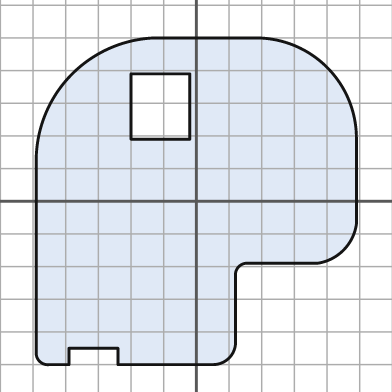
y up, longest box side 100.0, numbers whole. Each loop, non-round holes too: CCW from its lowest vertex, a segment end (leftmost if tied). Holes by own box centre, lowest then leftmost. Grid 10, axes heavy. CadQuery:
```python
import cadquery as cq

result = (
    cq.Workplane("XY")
    .moveTo(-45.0, -50.0)
    .lineTo(-39.0, -50.0)
    .lineTo(-39.0, -45.0)
    .lineTo(-24.0, -45.0)
    .lineTo(-24.0, -50.0)
    .lineTo(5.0, -50.0)
    .threePointArc((10.0, -48.0), (12.0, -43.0))
    .lineTo(12.0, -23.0)
    .threePointArc((13.0, -20.0), (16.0, -19.0))
    .lineTo(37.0, -19.0)
    .threePointArc((45.0, -15.0), (49.0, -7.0))
    .lineTo(49.0, 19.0)
    .threePointArc((40.0, 41.0), (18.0, 50.0))
    .lineTo(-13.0, 50.0)
    .threePointArc((-38.0, 39.0), (-49.0, 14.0))
    .lineTo(-49.0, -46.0)
    .threePointArc((-48.0, -49.0), (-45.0, -50.0))
    .close()
    .moveTo(-20.0, 19.0)
    .lineTo(-2.0, 19.0)
    .lineTo(-2.0, 39.0)
    .lineTo(-20.0, 39.0)
    .close()
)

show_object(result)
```